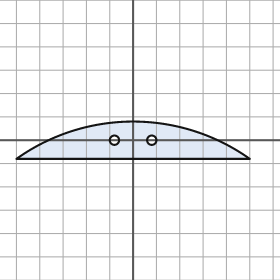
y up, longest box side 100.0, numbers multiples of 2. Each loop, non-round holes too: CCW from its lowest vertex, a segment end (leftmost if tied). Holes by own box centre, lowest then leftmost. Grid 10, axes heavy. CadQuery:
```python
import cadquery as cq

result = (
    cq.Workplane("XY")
    .moveTo(-50.0, -8.0)
    .lineTo(50.0, -8.0)
    .threePointArc((0.0, 8.0), (-50.0, -8.0))
    .close()
    .moveTo(-8.0, 0.0)
    .circle(2.0)
    .moveTo(8.0, 0.0)
    .circle(2.0)
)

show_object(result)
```